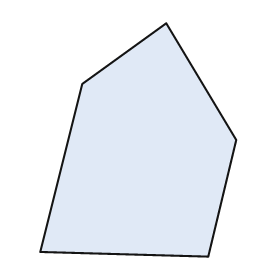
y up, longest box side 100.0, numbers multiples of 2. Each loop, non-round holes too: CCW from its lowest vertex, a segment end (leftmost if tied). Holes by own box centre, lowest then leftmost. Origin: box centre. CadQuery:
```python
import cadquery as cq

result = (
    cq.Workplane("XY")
    .moveTo(30.0, -50.0)
    .lineTo(42.0, 0.0)
    .lineTo(12.0, 50.0)
    .lineTo(-24.0, 24.0)
    .lineTo(-42.0, -48.0)
    .close()
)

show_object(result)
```